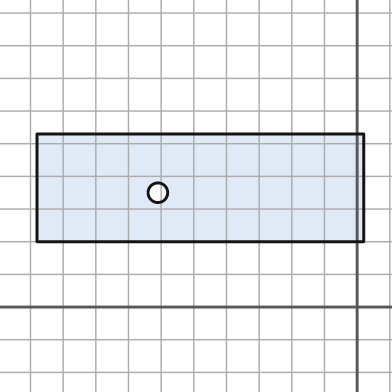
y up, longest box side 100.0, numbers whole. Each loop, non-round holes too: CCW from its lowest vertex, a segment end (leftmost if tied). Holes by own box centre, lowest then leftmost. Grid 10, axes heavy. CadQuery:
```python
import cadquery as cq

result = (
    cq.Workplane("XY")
    .moveTo(-98.0, 20.0)
    .lineTo(2.0, 20.0)
    .lineTo(2.0, 53.0)
    .lineTo(-98.0, 53.0)
    .close()
    .moveTo(-61.0, 35.0)
    .circle(3.0)
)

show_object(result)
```